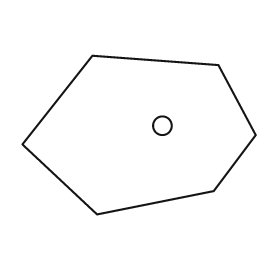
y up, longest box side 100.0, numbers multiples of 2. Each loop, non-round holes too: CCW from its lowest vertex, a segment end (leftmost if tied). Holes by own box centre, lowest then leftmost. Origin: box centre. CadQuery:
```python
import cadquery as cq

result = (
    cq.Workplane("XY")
    .moveTo(-18.0, -34.0)
    .lineTo(32.0, -24.0)
    .lineTo(50.0, 0.0)
    .lineTo(34.0, 30.0)
    .lineTo(-20.0, 34.0)
    .lineTo(-50.0, -4.0)
    .close()
    .moveTo(10.0, 4.0)
    .circle(4.0)
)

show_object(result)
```